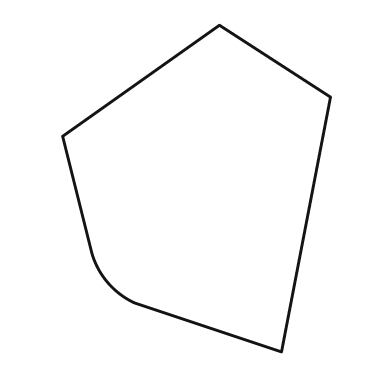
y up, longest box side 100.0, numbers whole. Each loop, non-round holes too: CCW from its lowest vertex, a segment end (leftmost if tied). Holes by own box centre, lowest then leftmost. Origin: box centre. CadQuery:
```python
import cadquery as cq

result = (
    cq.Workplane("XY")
    .moveTo(26.0, -50.0)
    .lineTo(41.0, 28.0)
    .lineTo(7.0, 50.0)
    .lineTo(-41.0, 16.0)
    .lineTo(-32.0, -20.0)
    .threePointArc((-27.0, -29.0), (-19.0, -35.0))
    .close()
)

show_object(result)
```